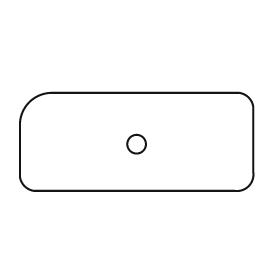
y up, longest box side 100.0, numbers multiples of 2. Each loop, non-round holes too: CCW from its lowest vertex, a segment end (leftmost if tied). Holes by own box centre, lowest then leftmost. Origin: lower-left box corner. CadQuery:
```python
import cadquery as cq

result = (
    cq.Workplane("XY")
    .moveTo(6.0, 0.0)
    .lineTo(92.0, 0.0)
    .threePointArc((98.0, 2.0), (100.0, 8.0))
    .lineTo(100.0, 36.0)
    .threePointArc((98.0, 40.0), (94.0, 42.0))
    .lineTo(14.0, 42.0)
    .threePointArc((4.0, 38.0), (0.0, 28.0))
    .lineTo(0.0, 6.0)
    .threePointArc((2.0, 2.0), (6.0, 0.0))
    .close()
    .moveTo(50.0, 20.0)
    .circle(4.0)
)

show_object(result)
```